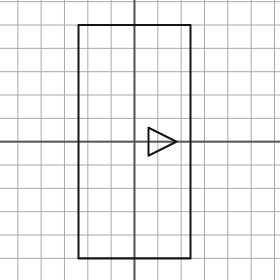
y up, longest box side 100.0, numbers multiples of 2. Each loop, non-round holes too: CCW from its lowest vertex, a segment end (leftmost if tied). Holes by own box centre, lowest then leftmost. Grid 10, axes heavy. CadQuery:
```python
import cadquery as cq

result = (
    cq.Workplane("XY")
    .moveTo(-24.0, -50.0)
    .lineTo(24.0, -50.0)
    .lineTo(24.0, 50.0)
    .lineTo(-24.0, 50.0)
    .close()
    .moveTo(6.0, -6.0)
    .lineTo(18.0, 0.0)
    .lineTo(6.0, 6.0)
    .close()
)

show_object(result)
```